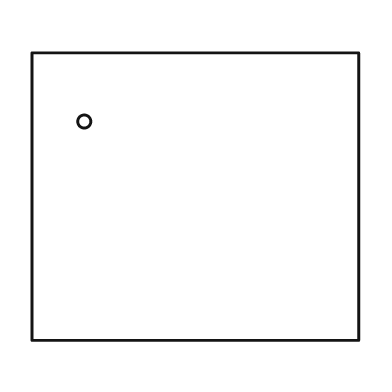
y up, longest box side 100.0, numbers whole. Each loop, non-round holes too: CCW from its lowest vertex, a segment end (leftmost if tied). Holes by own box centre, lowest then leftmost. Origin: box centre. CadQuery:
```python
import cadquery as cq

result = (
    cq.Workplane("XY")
    .moveTo(-50.0, -44.0)
    .lineTo(50.0, -44.0)
    .lineTo(50.0, 44.0)
    .lineTo(-50.0, 44.0)
    .close()
    .moveTo(-34.0, 23.0)
    .circle(2.0)
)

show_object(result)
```